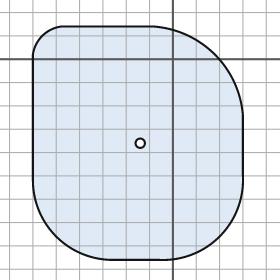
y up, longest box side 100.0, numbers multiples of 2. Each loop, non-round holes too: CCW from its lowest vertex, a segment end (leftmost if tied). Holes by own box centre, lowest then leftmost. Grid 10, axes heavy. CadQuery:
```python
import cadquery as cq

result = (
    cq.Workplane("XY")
    .moveTo(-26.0, -86.0)
    .lineTo(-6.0, -86.0)
    .threePointArc((20.0, -76.0), (30.0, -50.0))
    .lineTo(30.0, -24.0)
    .threePointArc((18.0, 2.0), (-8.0, 14.0))
    .lineTo(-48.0, 14.0)
    .threePointArc((-56.0, 10.0), (-60.0, 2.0))
    .lineTo(-60.0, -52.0)
    .threePointArc((-50.0, -76.0), (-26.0, -86.0))
    .close()
    .moveTo(-14.0, -36.0)
    .circle(2.0)
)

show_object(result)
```